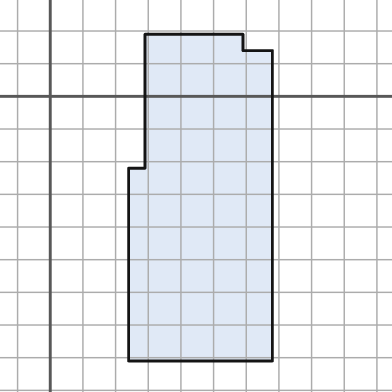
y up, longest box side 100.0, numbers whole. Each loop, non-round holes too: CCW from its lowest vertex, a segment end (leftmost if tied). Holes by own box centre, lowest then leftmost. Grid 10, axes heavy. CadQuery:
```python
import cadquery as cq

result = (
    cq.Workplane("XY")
    .moveTo(24.0, -81.0)
    .lineTo(68.0, -81.0)
    .lineTo(68.0, 14.0)
    .lineTo(59.0, 14.0)
    .lineTo(59.0, 19.0)
    .lineTo(29.0, 19.0)
    .lineTo(29.0, -22.0)
    .lineTo(24.0, -22.0)
    .close()
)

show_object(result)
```